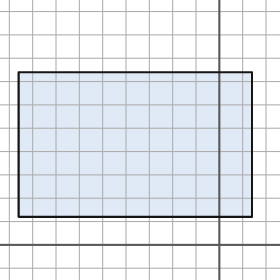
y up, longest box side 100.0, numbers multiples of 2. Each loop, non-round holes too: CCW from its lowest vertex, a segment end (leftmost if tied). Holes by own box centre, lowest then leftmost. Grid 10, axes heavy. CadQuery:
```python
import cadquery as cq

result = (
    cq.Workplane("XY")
    .moveTo(-86.0, 12.0)
    .lineTo(14.0, 12.0)
    .lineTo(14.0, 74.0)
    .lineTo(-86.0, 74.0)
    .close()
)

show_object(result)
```